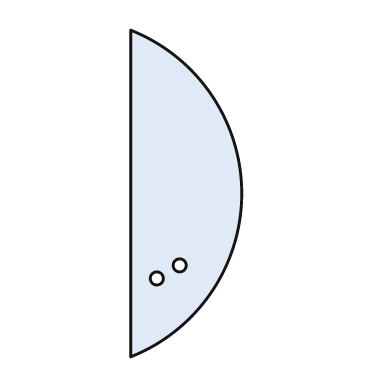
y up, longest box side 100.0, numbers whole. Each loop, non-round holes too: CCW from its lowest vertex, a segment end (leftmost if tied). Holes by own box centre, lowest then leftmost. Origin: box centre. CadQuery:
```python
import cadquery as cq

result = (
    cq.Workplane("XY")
    .moveTo(-17.0, -50.0)
    .threePointArc((17.0, 0.0), (-17.0, 50.0))
    .close()
    .moveTo(-9.0, -26.0)
    .circle(2.0)
    .moveTo(-2.0, -22.0)
    .circle(2.0)
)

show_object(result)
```